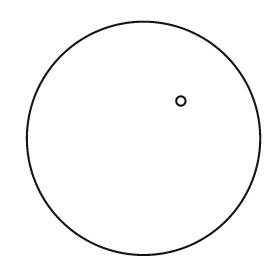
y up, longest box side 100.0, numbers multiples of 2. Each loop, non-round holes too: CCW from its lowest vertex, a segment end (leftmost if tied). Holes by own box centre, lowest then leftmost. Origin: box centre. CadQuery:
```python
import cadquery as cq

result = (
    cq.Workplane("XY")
    .moveTo(0.0, 0.0)
    .circle(50.0)
    .moveTo(16.0, 16.0)
    .circle(2.0)
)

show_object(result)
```